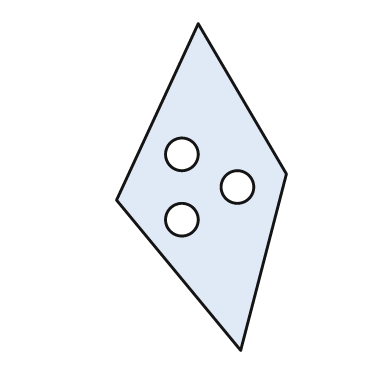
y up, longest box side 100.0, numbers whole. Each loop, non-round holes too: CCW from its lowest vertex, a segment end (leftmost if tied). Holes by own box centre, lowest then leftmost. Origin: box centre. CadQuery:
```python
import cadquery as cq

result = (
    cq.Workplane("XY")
    .moveTo(12.0, -50.0)
    .lineTo(26.0, 4.0)
    .lineTo(-1.0, 50.0)
    .lineTo(-26.0, -4.0)
    .close()
    .moveTo(-6.0, -10.0)
    .circle(5.0)
    .moveTo(11.0, 0.0)
    .circle(5.0)
    .moveTo(-6.0, 10.0)
    .circle(5.0)
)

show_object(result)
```